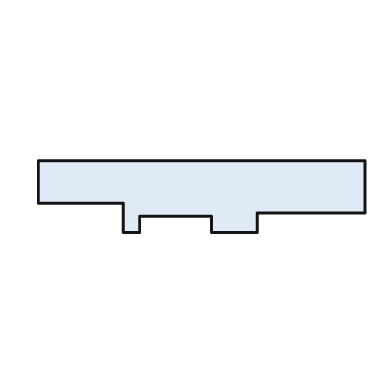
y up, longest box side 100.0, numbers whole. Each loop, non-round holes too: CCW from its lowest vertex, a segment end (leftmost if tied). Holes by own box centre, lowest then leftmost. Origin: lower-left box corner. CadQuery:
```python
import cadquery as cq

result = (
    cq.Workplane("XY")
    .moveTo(26.0, 0.0)
    .lineTo(31.0, 0.0)
    .lineTo(31.0, 5.0)
    .lineTo(53.0, 5.0)
    .lineTo(53.0, 0.0)
    .lineTo(67.0, 0.0)
    .lineTo(67.0, 6.0)
    .lineTo(100.0, 6.0)
    .lineTo(100.0, 22.0)
    .lineTo(0.0, 22.0)
    .lineTo(0.0, 9.0)
    .lineTo(26.0, 9.0)
    .close()
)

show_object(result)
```